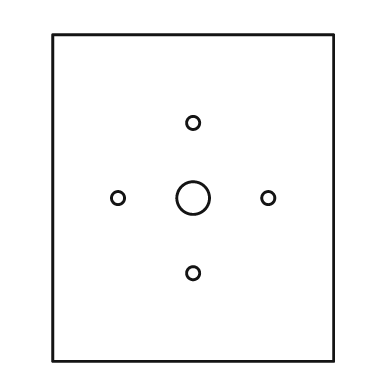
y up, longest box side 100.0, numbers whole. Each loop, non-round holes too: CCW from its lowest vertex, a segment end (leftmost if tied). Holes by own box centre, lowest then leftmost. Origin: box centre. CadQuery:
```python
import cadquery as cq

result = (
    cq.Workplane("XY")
    .moveTo(-43.0, -50.0)
    .lineTo(43.0, -50.0)
    .lineTo(43.0, 50.0)
    .lineTo(-43.0, 50.0)
    .close()
    .moveTo(0.0, -23.0)
    .circle(2.0)
    .moveTo(-23.0, 0.0)
    .circle(2.0)
    .moveTo(0.0, 0.0)
    .circle(5.0)
    .moveTo(23.0, 0.0)
    .circle(2.0)
    .moveTo(0.0, 23.0)
    .circle(2.0)
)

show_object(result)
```